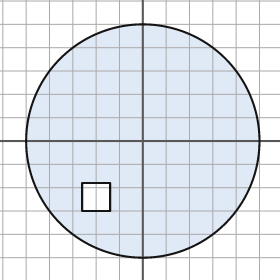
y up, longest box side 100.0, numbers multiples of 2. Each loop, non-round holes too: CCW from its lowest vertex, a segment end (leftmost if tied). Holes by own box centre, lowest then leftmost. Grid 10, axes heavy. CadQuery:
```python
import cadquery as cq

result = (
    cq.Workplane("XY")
    .moveTo(0.0, 0.0)
    .circle(50.0)
    .moveTo(-26.0, -30.0)
    .lineTo(-14.0, -30.0)
    .lineTo(-14.0, -18.0)
    .lineTo(-26.0, -18.0)
    .close()
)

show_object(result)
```